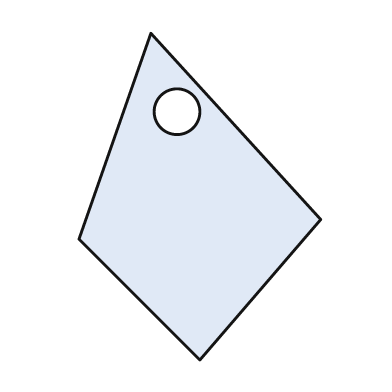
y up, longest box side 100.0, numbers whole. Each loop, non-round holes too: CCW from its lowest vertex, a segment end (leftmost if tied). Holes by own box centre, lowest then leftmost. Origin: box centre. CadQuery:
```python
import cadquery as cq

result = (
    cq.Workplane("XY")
    .moveTo(0.0, -50.0)
    .lineTo(37.0, -7.0)
    .lineTo(-15.0, 50.0)
    .lineTo(-37.0, -13.0)
    .close()
    .moveTo(-7.0, 26.0)
    .circle(7.0)
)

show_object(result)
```